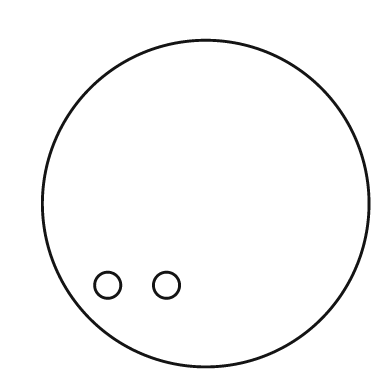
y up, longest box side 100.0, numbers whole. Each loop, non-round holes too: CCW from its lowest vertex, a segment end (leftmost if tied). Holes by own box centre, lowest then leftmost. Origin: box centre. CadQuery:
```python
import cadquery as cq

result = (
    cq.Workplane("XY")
    .moveTo(0.0, 0.0)
    .circle(50.0)
    .moveTo(-30.0, -25.0)
    .circle(4.0)
    .moveTo(-12.0, -25.0)
    .circle(4.0)
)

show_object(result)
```